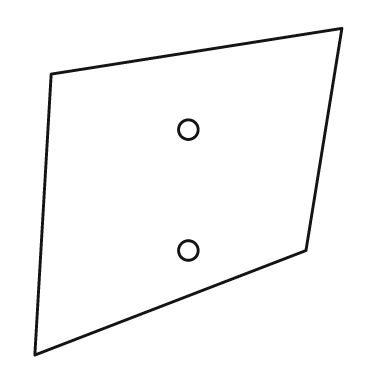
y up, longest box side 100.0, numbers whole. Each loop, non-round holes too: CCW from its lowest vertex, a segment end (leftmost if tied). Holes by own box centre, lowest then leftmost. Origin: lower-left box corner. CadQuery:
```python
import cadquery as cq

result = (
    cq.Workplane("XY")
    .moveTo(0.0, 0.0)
    .lineTo(83.0, 32.0)
    .lineTo(94.0, 100.0)
    .lineTo(5.0, 86.0)
    .close()
    .moveTo(47.0, 32.0)
    .circle(3.0)
    .moveTo(47.0, 69.0)
    .circle(3.0)
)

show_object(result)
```